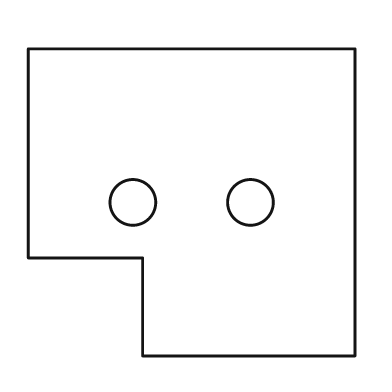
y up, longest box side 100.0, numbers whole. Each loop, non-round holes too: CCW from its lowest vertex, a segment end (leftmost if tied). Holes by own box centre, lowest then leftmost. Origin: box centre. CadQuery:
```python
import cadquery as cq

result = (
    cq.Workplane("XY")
    .moveTo(-15.0, -47.0)
    .lineTo(50.0, -47.0)
    .lineTo(50.0, 47.0)
    .lineTo(-50.0, 47.0)
    .lineTo(-50.0, -17.0)
    .lineTo(-15.0, -17.0)
    .close()
    .moveTo(-18.0, 0.0)
    .circle(7.0)
    .moveTo(18.0, 0.0)
    .circle(7.0)
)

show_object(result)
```